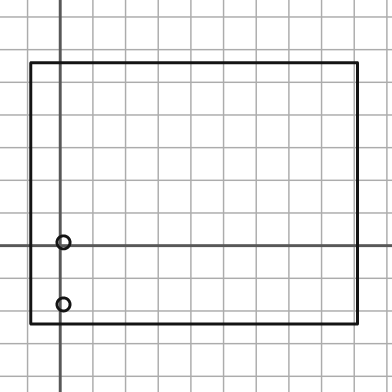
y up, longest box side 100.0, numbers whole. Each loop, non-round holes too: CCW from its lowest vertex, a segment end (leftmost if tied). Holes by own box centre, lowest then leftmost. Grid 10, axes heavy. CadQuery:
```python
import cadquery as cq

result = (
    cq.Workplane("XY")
    .moveTo(-9.0, -24.0)
    .lineTo(91.0, -24.0)
    .lineTo(91.0, 56.0)
    .lineTo(-9.0, 56.0)
    .close()
    .moveTo(1.0, -18.0)
    .circle(2.0)
    .moveTo(1.0, 1.0)
    .circle(2.0)
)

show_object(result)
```